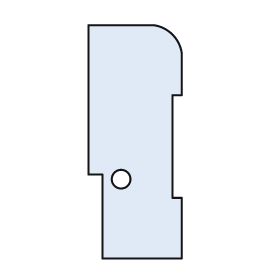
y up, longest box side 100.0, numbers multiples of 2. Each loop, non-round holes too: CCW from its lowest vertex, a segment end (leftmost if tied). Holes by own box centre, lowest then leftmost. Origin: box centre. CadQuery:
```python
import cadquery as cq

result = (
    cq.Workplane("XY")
    .moveTo(-14.0, -50.0)
    .lineTo(20.0, -50.0)
    .lineTo(20.0, -24.0)
    .lineTo(16.0, -24.0)
    .lineTo(16.0, 20.0)
    .lineTo(20.0, 20.0)
    .lineTo(20.0, 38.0)
    .threePointArc((16.0, 46.0), (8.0, 50.0))
    .lineTo(-20.0, 50.0)
    .lineTo(-20.0, -14.0)
    .lineTo(-14.0, -14.0)
    .close()
    .moveTo(-6.0, -16.0)
    .circle(4.0)
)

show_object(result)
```